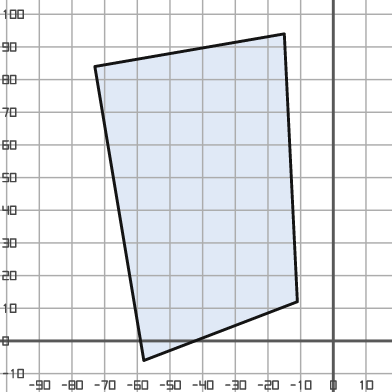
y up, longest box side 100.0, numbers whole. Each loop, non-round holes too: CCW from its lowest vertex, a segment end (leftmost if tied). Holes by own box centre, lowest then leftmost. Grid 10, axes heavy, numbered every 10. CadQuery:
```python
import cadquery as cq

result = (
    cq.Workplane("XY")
    .moveTo(-58.0, -6.0)
    .lineTo(-11.0, 12.0)
    .lineTo(-15.0, 94.0)
    .lineTo(-73.0, 84.0)
    .close()
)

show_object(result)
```